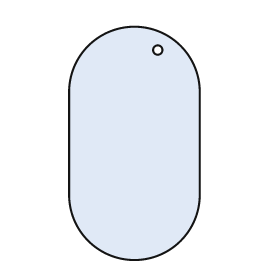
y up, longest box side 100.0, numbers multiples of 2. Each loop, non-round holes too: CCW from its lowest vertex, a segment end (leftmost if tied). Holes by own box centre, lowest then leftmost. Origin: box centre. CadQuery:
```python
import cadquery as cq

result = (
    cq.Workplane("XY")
    .moveTo(-28.0, -22.0)
    .threePointArc((0.0, -50.0), (28.0, -22.0))
    .lineTo(28.0, 22.0)
    .threePointArc((0.0, 50.0), (-28.0, 22.0))
    .close()
    .moveTo(10.0, 40.0)
    .circle(2.0)
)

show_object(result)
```